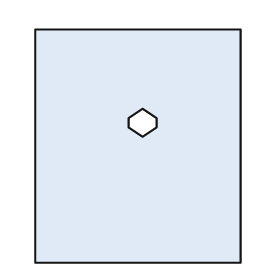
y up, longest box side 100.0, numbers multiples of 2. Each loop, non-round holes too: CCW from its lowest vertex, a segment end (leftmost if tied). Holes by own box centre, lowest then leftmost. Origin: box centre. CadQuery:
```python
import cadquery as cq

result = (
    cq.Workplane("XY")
    .moveTo(-44.0, -50.0)
    .lineTo(44.0, -50.0)
    .lineTo(44.0, 50.0)
    .lineTo(-44.0, 50.0)
    .close()
    .moveTo(2.0, 4.0)
    .lineTo(8.0, 8.0)
    .lineTo(8.0, 12.0)
    .lineTo(2.0, 16.0)
    .lineTo(-4.0, 12.0)
    .lineTo(-4.0, 8.0)
    .close()
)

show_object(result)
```